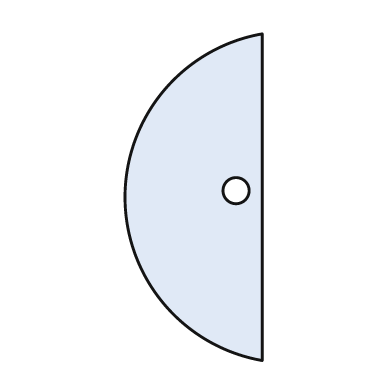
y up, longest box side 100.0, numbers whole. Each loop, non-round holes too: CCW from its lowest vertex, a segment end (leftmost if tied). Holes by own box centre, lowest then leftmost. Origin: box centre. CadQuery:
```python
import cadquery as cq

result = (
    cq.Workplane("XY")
    .moveTo(21.0, -50.0)
    .lineTo(21.0, 50.0)
    .threePointArc((-21.0, 0.0), (21.0, -50.0))
    .close()
    .moveTo(13.0, 2.0)
    .circle(4.0)
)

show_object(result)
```